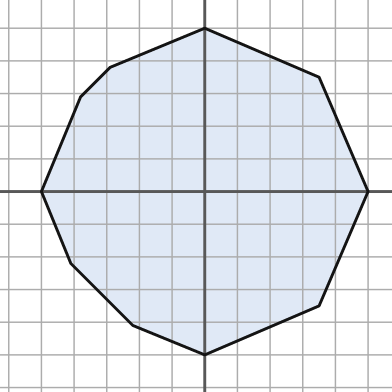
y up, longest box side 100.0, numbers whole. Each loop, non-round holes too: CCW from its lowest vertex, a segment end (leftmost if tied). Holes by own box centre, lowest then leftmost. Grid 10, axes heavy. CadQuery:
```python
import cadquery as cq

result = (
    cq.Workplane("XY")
    .moveTo(0.0, -50.0)
    .lineTo(35.0, -35.0)
    .lineTo(50.0, 0.0)
    .lineTo(35.0, 35.0)
    .lineTo(0.0, 50.0)
    .lineTo(-29.0, 38.0)
    .lineTo(-38.0, 29.0)
    .lineTo(-50.0, 0.0)
    .lineTo(-41.0, -22.0)
    .lineTo(-22.0, -41.0)
    .close()
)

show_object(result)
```